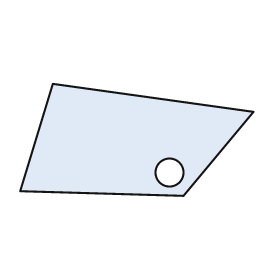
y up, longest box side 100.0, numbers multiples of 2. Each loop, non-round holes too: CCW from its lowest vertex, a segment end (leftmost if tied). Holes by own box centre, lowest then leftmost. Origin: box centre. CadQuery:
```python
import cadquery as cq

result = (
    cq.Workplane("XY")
    .moveTo(20.0, -24.0)
    .lineTo(50.0, 12.0)
    .lineTo(-36.0, 24.0)
    .lineTo(-50.0, -22.0)
    .close()
    .moveTo(14.0, -14.0)
    .circle(6.0)
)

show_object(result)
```